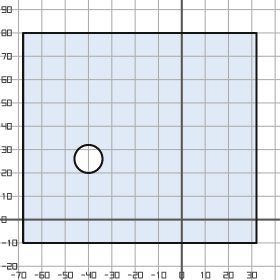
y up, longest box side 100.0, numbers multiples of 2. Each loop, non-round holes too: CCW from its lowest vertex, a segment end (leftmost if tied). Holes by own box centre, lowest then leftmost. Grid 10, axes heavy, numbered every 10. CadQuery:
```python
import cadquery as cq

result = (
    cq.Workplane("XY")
    .moveTo(-68.0, -10.0)
    .lineTo(32.0, -10.0)
    .lineTo(32.0, 80.0)
    .lineTo(-68.0, 80.0)
    .close()
    .moveTo(-40.0, 26.0)
    .circle(6.0)
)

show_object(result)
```